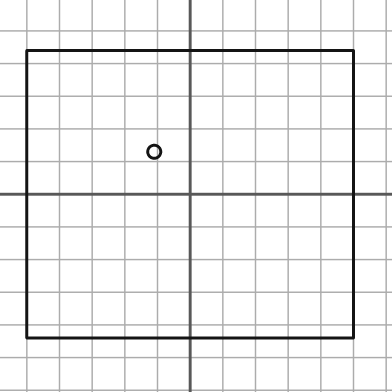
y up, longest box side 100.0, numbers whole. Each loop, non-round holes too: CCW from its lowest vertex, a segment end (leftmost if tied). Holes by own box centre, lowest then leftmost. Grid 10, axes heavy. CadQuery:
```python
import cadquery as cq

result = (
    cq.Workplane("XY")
    .moveTo(-50.0, -44.0)
    .lineTo(50.0, -44.0)
    .lineTo(50.0, 44.0)
    .lineTo(-50.0, 44.0)
    .close()
    .moveTo(-11.0, 13.0)
    .circle(2.0)
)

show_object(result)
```